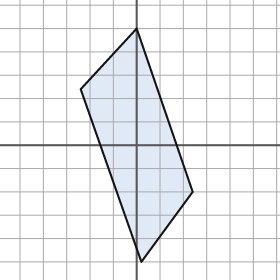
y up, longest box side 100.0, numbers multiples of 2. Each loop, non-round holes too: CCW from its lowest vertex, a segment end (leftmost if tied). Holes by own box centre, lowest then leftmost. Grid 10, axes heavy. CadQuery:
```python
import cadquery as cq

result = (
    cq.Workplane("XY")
    .moveTo(2.0, -50.0)
    .lineTo(24.0, -20.0)
    .lineTo(0.0, 50.0)
    .lineTo(-24.0, 24.0)
    .close()
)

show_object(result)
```